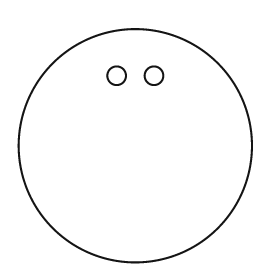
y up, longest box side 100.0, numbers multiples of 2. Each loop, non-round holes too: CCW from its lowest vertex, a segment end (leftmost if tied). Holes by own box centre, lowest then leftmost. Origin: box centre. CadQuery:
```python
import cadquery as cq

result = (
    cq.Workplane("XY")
    .moveTo(0.0, 0.0)
    .circle(50.0)
    .moveTo(-8.0, 30.0)
    .circle(4.0)
    .moveTo(8.0, 30.0)
    .circle(4.0)
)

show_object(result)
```